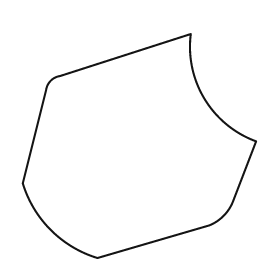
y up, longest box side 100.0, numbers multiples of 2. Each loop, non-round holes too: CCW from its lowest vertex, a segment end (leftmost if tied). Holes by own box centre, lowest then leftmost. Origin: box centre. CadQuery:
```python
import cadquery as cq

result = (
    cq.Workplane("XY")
    .moveTo(-18.0, -48.0)
    .lineTo(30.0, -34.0)
    .threePointArc((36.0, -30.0), (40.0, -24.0))
    .lineTo(50.0, 2.0)
    .threePointArc((28.0, 20.0), (22.0, 48.0))
    .lineTo(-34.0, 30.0)
    .threePointArc((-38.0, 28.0), (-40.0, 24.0))
    .lineTo(-50.0, -16.0)
    .threePointArc((-38.0, -36.0), (-18.0, -48.0))
    .close()
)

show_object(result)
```